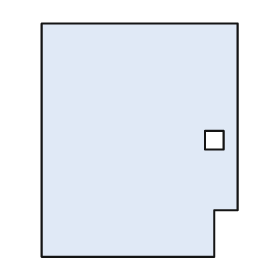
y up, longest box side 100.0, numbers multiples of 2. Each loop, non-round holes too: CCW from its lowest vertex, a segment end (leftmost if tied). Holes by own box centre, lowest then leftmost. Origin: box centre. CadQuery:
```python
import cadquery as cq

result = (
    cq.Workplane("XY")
    .moveTo(-42.0, -50.0)
    .lineTo(32.0, -50.0)
    .lineTo(32.0, -30.0)
    .lineTo(42.0, -30.0)
    .lineTo(42.0, 50.0)
    .lineTo(-42.0, 50.0)
    .close()
    .moveTo(28.0, -4.0)
    .lineTo(36.0, -4.0)
    .lineTo(36.0, 4.0)
    .lineTo(28.0, 4.0)
    .close()
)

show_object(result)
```